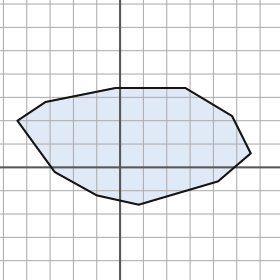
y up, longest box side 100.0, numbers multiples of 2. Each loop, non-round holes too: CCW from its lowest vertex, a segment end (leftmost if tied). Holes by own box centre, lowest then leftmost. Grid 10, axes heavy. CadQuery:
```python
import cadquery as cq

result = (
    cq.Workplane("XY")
    .moveTo(8.0, -16.0)
    .lineTo(42.0, -6.0)
    .lineTo(56.0, 6.0)
    .lineTo(48.0, 22.0)
    .lineTo(28.0, 34.0)
    .lineTo(-2.0, 34.0)
    .lineTo(-32.0, 28.0)
    .lineTo(-44.0, 20.0)
    .lineTo(-28.0, -2.0)
    .lineTo(-10.0, -12.0)
    .close()
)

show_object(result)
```